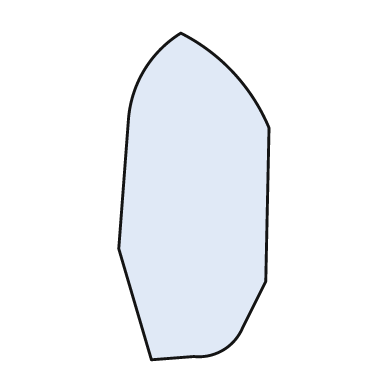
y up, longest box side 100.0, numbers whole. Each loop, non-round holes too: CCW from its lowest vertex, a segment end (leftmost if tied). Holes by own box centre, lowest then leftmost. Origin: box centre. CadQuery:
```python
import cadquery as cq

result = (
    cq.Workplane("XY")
    .moveTo(-13.0, -50.0)
    .lineTo(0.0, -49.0)
    .threePointArc((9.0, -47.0), (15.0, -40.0))
    .lineTo(22.0, -26.0)
    .lineTo(23.0, 21.0)
    .threePointArc((12.0, 38.0), (-4.0, 50.0))
    .threePointArc((-15.0, 39.0), (-20.0, 24.0))
    .lineTo(-23.0, -16.0)
    .close()
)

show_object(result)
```